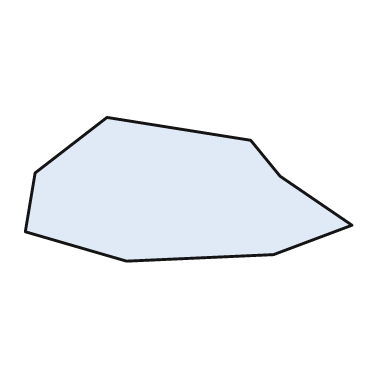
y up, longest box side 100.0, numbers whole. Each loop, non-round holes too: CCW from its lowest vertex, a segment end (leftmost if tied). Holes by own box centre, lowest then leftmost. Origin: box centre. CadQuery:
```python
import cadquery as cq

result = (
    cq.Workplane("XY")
    .moveTo(-19.0, -22.0)
    .lineTo(26.0, -20.0)
    .lineTo(50.0, -11.0)
    .lineTo(28.0, 4.0)
    .lineTo(19.0, 15.0)
    .lineTo(-25.0, 22.0)
    .lineTo(-47.0, 5.0)
    .lineTo(-50.0, -13.0)
    .close()
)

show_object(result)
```